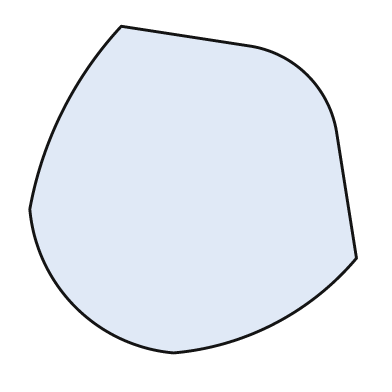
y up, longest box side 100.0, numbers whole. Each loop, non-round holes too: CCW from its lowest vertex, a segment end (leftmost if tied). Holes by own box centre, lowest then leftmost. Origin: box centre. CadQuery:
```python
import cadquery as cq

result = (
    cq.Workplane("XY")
    .moveTo(-6.0, -50.0)
    .threePointArc((25.0, -41.0), (50.0, -21.0))
    .lineTo(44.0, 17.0)
    .threePointArc((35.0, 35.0), (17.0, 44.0))
    .lineTo(-22.0, 50.0)
    .threePointArc((-40.0, 24.0), (-50.0, -6.0))
    .threePointArc((-36.0, -36.0), (-6.0, -50.0))
    .close()
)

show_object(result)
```